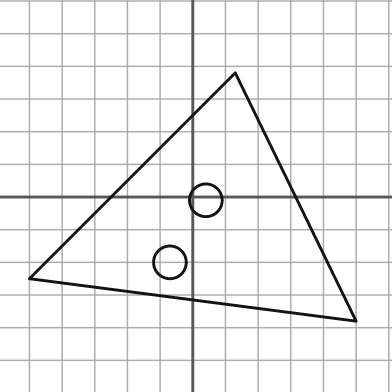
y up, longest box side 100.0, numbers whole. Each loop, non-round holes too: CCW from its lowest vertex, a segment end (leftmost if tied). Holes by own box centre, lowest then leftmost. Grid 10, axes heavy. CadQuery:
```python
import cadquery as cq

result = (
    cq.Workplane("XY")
    .moveTo(50.0, -38.0)
    .lineTo(13.0, 38.0)
    .lineTo(-50.0, -25.0)
    .close()
    .moveTo(-7.0, -20.0)
    .circle(5.0)
    .moveTo(4.0, -1.0)
    .circle(5.0)
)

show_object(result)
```